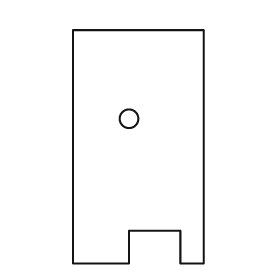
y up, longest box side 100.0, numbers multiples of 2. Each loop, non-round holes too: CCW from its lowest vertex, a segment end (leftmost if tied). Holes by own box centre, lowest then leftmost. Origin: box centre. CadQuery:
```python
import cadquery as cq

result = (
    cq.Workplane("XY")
    .moveTo(-28.0, -50.0)
    .lineTo(-4.0, -50.0)
    .lineTo(-4.0, -36.0)
    .lineTo(18.0, -36.0)
    .lineTo(18.0, -50.0)
    .lineTo(28.0, -50.0)
    .lineTo(28.0, 50.0)
    .lineTo(-28.0, 50.0)
    .close()
    .moveTo(-4.0, 12.0)
    .circle(4.0)
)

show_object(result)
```